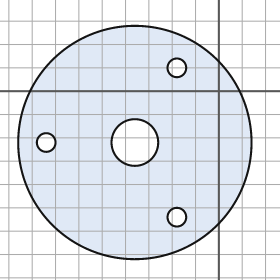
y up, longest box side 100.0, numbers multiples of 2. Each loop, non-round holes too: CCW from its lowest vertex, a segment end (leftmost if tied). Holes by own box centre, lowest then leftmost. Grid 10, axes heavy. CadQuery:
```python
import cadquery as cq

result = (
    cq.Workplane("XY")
    .moveTo(-36.0, -22.0)
    .circle(50.0)
    .moveTo(-18.0, -54.0)
    .circle(4.0)
    .moveTo(-74.0, -22.0)
    .circle(4.0)
    .moveTo(-36.0, -22.0)
    .circle(10.0)
    .moveTo(-18.0, 10.0)
    .circle(4.0)
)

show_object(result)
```